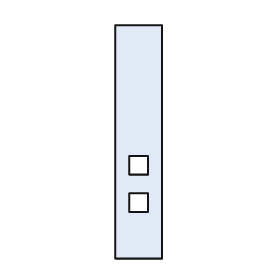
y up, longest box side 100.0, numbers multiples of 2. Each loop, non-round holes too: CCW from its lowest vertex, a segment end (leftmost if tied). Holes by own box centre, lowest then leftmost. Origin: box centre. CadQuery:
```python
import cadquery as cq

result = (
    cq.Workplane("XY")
    .moveTo(-10.0, -50.0)
    .lineTo(10.0, -50.0)
    .lineTo(10.0, 50.0)
    .lineTo(-10.0, 50.0)
    .close()
    .moveTo(-4.0, -30.0)
    .lineTo(4.0, -30.0)
    .lineTo(4.0, -22.0)
    .lineTo(-4.0, -22.0)
    .close()
    .moveTo(-4.0, -14.0)
    .lineTo(4.0, -14.0)
    .lineTo(4.0, -6.0)
    .lineTo(-4.0, -6.0)
    .close()
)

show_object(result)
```